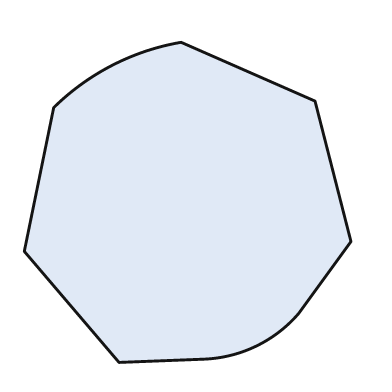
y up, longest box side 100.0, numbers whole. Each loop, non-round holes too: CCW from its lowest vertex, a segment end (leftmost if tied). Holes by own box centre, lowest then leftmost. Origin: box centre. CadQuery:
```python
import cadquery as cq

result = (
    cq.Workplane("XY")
    .moveTo(-21.0, -49.0)
    .lineTo(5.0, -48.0)
    .threePointArc((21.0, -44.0), (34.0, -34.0))
    .lineTo(50.0, -12.0)
    .lineTo(39.0, 31.0)
    .lineTo(-2.0, 49.0)
    .threePointArc((-23.0, 42.0), (-41.0, 29.0))
    .lineTo(-50.0, -15.0)
    .close()
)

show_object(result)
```